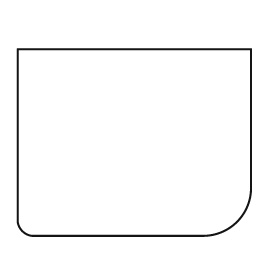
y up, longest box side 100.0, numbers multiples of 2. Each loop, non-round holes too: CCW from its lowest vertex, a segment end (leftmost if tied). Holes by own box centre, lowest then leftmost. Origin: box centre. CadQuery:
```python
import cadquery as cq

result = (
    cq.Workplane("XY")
    .moveTo(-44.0, -40.0)
    .lineTo(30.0, -40.0)
    .threePointArc((44.0, -34.0), (50.0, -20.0))
    .lineTo(50.0, 40.0)
    .lineTo(-50.0, 40.0)
    .lineTo(-50.0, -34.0)
    .threePointArc((-48.0, -38.0), (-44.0, -40.0))
    .close()
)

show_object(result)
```